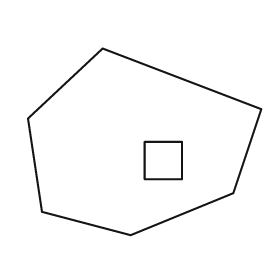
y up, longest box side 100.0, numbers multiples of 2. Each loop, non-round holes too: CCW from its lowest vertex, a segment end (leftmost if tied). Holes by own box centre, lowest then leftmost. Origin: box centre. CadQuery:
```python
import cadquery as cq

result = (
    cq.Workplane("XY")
    .moveTo(-6.0, -40.0)
    .lineTo(38.0, -22.0)
    .lineTo(50.0, 14.0)
    .lineTo(-18.0, 40.0)
    .lineTo(-50.0, 10.0)
    .lineTo(-44.0, -30.0)
    .close()
    .moveTo(0.0, -16.0)
    .lineTo(16.0, -16.0)
    .lineTo(16.0, 0.0)
    .lineTo(0.0, 0.0)
    .close()
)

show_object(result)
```